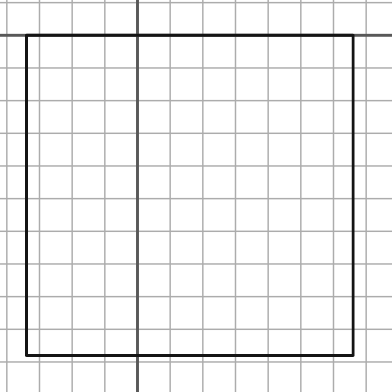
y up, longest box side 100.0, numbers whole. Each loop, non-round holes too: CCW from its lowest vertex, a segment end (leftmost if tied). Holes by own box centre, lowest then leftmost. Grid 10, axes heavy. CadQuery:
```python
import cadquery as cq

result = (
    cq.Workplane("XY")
    .moveTo(-34.0, -98.0)
    .lineTo(66.0, -98.0)
    .lineTo(66.0, 0.0)
    .lineTo(-34.0, 0.0)
    .close()
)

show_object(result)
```